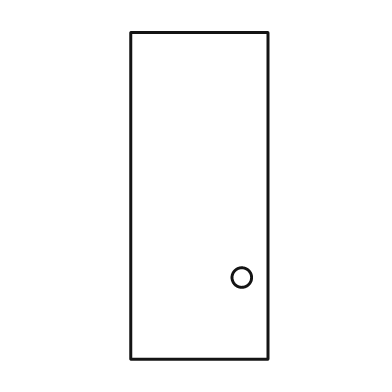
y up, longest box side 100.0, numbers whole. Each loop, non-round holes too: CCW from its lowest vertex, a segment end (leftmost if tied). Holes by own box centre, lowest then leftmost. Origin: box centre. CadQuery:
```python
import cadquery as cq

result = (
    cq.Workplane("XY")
    .moveTo(-21.0, -50.0)
    .lineTo(21.0, -50.0)
    .lineTo(21.0, 50.0)
    .lineTo(-21.0, 50.0)
    .close()
    .moveTo(13.0, -25.0)
    .circle(3.0)
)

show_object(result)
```